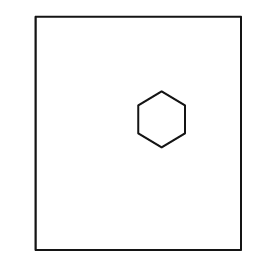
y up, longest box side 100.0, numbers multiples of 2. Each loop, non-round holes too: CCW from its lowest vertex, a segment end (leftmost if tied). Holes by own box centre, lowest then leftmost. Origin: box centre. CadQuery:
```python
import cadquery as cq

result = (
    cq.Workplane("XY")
    .moveTo(-44.0, -50.0)
    .lineTo(44.0, -50.0)
    .lineTo(44.0, 50.0)
    .lineTo(-44.0, 50.0)
    .close()
    .moveTo(10.0, -6.0)
    .lineTo(20.0, 0.0)
    .lineTo(20.0, 12.0)
    .lineTo(10.0, 18.0)
    .lineTo(0.0, 12.0)
    .lineTo(0.0, 0.0)
    .close()
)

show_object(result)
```